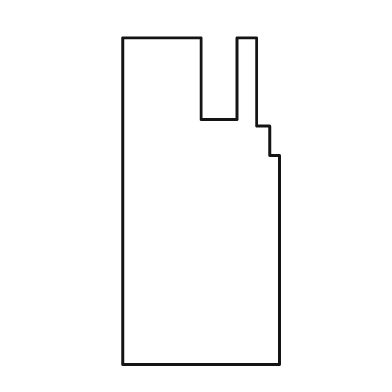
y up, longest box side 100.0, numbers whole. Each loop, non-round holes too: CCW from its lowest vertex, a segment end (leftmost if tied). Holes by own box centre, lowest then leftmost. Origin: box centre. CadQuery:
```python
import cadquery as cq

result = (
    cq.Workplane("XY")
    .moveTo(-24.0, -50.0)
    .lineTo(24.0, -50.0)
    .lineTo(24.0, 14.0)
    .lineTo(21.0, 14.0)
    .lineTo(21.0, 23.0)
    .lineTo(17.0, 23.0)
    .lineTo(17.0, 50.0)
    .lineTo(11.0, 50.0)
    .lineTo(11.0, 25.0)
    .lineTo(0.0, 25.0)
    .lineTo(0.0, 50.0)
    .lineTo(-24.0, 50.0)
    .close()
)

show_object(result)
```